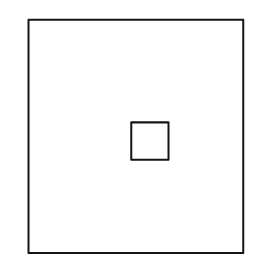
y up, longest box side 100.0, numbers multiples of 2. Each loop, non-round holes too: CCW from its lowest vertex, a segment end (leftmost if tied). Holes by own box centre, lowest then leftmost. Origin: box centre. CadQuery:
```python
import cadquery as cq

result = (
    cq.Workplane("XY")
    .moveTo(-46.0, -50.0)
    .lineTo(46.0, -50.0)
    .lineTo(46.0, 50.0)
    .lineTo(-46.0, 50.0)
    .close()
    .moveTo(-2.0, -10.0)
    .lineTo(14.0, -10.0)
    .lineTo(14.0, 6.0)
    .lineTo(-2.0, 6.0)
    .close()
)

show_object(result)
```